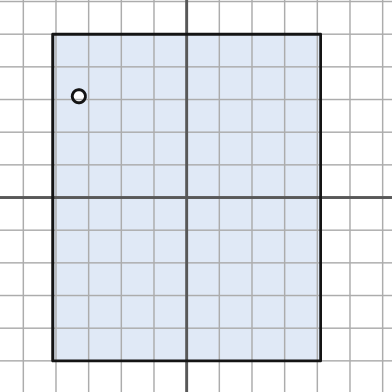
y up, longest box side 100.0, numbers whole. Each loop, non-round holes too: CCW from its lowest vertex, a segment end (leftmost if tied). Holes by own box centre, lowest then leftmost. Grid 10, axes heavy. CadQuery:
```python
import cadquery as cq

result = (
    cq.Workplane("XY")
    .moveTo(-41.0, -50.0)
    .lineTo(41.0, -50.0)
    .lineTo(41.0, 50.0)
    .lineTo(-41.0, 50.0)
    .close()
    .moveTo(-33.0, 31.0)
    .circle(2.0)
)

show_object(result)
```